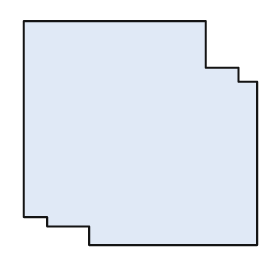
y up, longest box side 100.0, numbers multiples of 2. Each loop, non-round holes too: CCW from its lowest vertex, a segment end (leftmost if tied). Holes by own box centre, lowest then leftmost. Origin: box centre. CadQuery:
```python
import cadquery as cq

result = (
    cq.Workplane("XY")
    .moveTo(-22.0, -48.0)
    .lineTo(50.0, -48.0)
    .lineTo(50.0, 22.0)
    .lineTo(42.0, 22.0)
    .lineTo(42.0, 28.0)
    .lineTo(28.0, 28.0)
    .lineTo(28.0, 48.0)
    .lineTo(-50.0, 48.0)
    .lineTo(-50.0, -36.0)
    .lineTo(-40.0, -36.0)
    .lineTo(-40.0, -40.0)
    .lineTo(-22.0, -40.0)
    .close()
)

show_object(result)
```